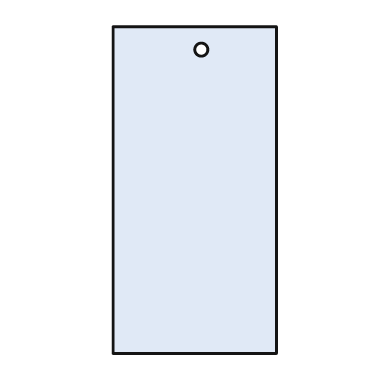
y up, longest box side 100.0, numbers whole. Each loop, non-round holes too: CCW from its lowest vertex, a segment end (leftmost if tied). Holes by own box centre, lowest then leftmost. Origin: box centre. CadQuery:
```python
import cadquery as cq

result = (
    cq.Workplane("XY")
    .moveTo(-25.0, -50.0)
    .lineTo(25.0, -50.0)
    .lineTo(25.0, 50.0)
    .lineTo(-25.0, 50.0)
    .close()
    .moveTo(2.0, 43.0)
    .circle(2.0)
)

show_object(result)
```